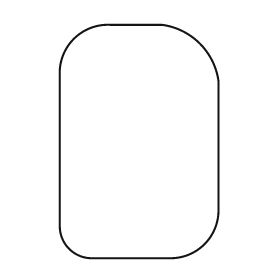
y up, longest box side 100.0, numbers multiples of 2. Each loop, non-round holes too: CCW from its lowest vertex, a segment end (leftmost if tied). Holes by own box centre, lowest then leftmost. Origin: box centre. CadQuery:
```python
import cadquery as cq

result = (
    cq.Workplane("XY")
    .moveTo(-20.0, -50.0)
    .lineTo(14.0, -50.0)
    .threePointArc((28.0, -44.0), (34.0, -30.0))
    .lineTo(34.0, 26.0)
    .threePointArc((26.0, 42.0), (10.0, 50.0))
    .lineTo(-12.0, 50.0)
    .threePointArc((-28.0, 44.0), (-34.0, 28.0))
    .lineTo(-34.0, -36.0)
    .threePointArc((-30.0, -46.0), (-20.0, -50.0))
    .close()
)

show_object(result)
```